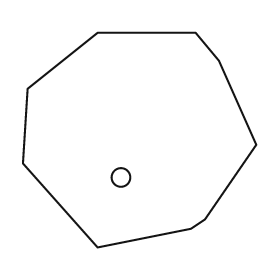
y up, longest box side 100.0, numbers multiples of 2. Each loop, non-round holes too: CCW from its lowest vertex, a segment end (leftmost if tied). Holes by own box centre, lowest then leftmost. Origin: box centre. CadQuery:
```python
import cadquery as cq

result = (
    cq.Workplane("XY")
    .moveTo(-18.0, -46.0)
    .lineTo(22.0, -38.0)
    .lineTo(28.0, -34.0)
    .lineTo(50.0, -2.0)
    .lineTo(34.0, 34.0)
    .lineTo(24.0, 46.0)
    .lineTo(-18.0, 46.0)
    .lineTo(-48.0, 22.0)
    .lineTo(-50.0, -10.0)
    .close()
    .moveTo(-8.0, -16.0)
    .circle(4.0)
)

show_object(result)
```